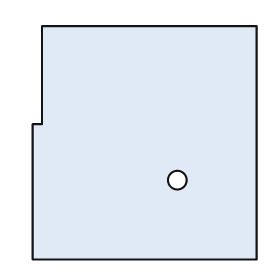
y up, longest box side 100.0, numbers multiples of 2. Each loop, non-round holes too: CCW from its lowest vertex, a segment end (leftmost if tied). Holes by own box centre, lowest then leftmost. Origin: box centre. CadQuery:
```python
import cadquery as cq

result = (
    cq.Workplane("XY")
    .moveTo(-48.0, -50.0)
    .lineTo(48.0, -50.0)
    .lineTo(48.0, 50.0)
    .lineTo(-44.0, 50.0)
    .lineTo(-44.0, 8.0)
    .lineTo(-48.0, 8.0)
    .close()
    .moveTo(14.0, -16.0)
    .circle(4.0)
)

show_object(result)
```